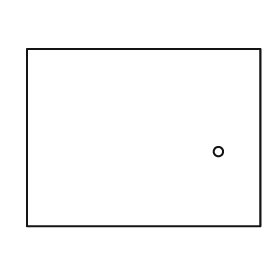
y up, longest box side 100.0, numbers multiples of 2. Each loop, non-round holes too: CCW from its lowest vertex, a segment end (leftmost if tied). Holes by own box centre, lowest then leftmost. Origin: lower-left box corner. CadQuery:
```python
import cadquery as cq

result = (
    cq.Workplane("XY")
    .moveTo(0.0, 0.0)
    .lineTo(100.0, 0.0)
    .lineTo(100.0, 76.0)
    .lineTo(0.0, 76.0)
    .close()
    .moveTo(82.0, 32.0)
    .circle(2.0)
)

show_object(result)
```